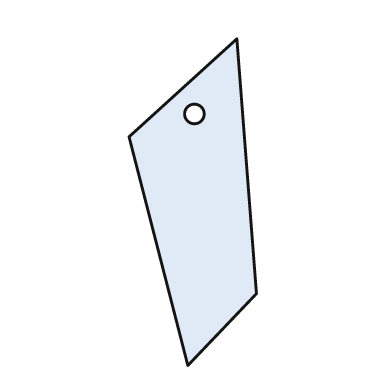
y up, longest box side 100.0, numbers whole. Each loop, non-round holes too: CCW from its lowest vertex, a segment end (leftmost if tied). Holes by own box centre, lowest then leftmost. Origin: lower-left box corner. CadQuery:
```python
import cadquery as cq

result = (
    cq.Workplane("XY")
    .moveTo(18.0, 0.0)
    .lineTo(39.0, 22.0)
    .lineTo(33.0, 100.0)
    .lineTo(0.0, 70.0)
    .close()
    .moveTo(20.0, 77.0)
    .circle(3.0)
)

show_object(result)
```